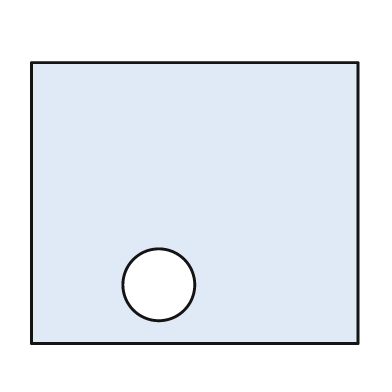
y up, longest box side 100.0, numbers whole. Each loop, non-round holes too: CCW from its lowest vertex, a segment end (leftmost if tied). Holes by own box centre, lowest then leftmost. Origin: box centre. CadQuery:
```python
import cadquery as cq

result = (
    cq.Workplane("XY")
    .moveTo(-50.0, -43.0)
    .lineTo(50.0, -43.0)
    .lineTo(50.0, 43.0)
    .lineTo(-50.0, 43.0)
    .close()
    .moveTo(-11.0, -25.0)
    .circle(11.0)
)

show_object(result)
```